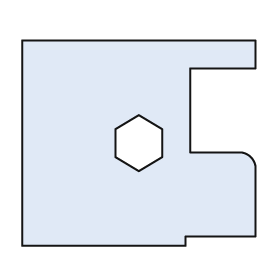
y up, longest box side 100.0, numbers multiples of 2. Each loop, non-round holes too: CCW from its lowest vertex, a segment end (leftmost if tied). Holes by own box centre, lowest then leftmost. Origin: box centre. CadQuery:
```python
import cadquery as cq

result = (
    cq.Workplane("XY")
    .moveTo(-50.0, -44.0)
    .lineTo(20.0, -44.0)
    .lineTo(20.0, -40.0)
    .lineTo(50.0, -40.0)
    .lineTo(50.0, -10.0)
    .threePointArc((48.0, -6.0), (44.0, -4.0))
    .lineTo(22.0, -4.0)
    .lineTo(22.0, 32.0)
    .lineTo(50.0, 32.0)
    .lineTo(50.0, 44.0)
    .lineTo(-50.0, 44.0)
    .close()
    .moveTo(0.0, -12.0)
    .lineTo(10.0, -6.0)
    .lineTo(10.0, 6.0)
    .lineTo(0.0, 12.0)
    .lineTo(-10.0, 6.0)
    .lineTo(-10.0, -6.0)
    .close()
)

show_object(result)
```